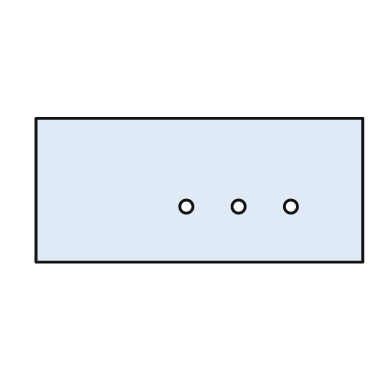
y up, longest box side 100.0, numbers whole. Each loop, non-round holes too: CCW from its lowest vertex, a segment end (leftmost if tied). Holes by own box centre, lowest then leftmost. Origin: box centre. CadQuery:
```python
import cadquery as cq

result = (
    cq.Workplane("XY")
    .moveTo(-50.0, -22.0)
    .lineTo(50.0, -22.0)
    .lineTo(50.0, 22.0)
    .lineTo(-50.0, 22.0)
    .close()
    .moveTo(-4.0, -5.0)
    .circle(2.0)
    .moveTo(12.0, -5.0)
    .circle(2.0)
    .moveTo(28.0, -5.0)
    .circle(2.0)
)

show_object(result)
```